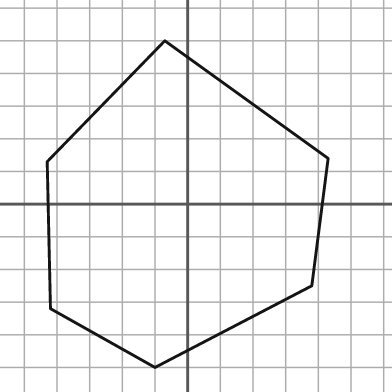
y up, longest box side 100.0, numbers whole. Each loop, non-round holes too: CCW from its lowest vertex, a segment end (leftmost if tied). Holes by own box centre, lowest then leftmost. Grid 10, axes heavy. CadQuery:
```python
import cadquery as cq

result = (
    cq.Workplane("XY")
    .moveTo(-10.0, -50.0)
    .lineTo(38.0, -25.0)
    .lineTo(43.0, 14.0)
    .lineTo(-7.0, 50.0)
    .lineTo(-43.0, 13.0)
    .lineTo(-42.0, -32.0)
    .close()
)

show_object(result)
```